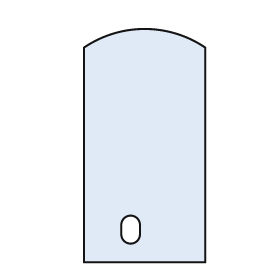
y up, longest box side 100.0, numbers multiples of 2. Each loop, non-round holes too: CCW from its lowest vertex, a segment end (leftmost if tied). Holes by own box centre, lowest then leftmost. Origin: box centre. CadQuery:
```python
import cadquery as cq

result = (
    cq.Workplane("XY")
    .moveTo(-26.0, -50.0)
    .lineTo(26.0, -50.0)
    .lineTo(26.0, 42.0)
    .threePointArc((0.0, 50.0), (-26.0, 42.0))
    .close()
    .moveTo(-10.0, -38.0)
    .threePointArc((-6.0, -42.0), (-2.0, -38.0))
    .lineTo(-2.0, -34.0)
    .threePointArc((-6.0, -30.0), (-10.0, -34.0))
    .close()
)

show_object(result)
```